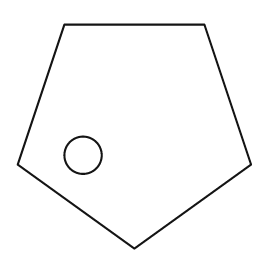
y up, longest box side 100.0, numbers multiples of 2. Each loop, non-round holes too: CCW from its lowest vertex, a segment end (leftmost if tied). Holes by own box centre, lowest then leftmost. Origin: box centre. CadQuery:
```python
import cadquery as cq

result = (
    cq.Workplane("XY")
    .moveTo(0.0, -48.0)
    .lineTo(50.0, -12.0)
    .lineTo(30.0, 48.0)
    .lineTo(-30.0, 48.0)
    .lineTo(-50.0, -12.0)
    .close()
    .moveTo(-22.0, -8.0)
    .circle(8.0)
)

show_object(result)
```